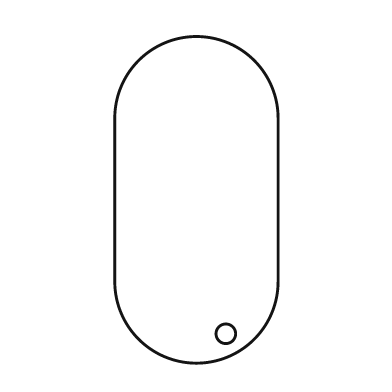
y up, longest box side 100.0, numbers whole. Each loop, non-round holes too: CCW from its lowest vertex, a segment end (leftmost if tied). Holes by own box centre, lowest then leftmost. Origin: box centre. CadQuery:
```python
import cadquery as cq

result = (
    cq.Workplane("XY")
    .moveTo(-25.0, -25.0)
    .threePointArc((0.0, -50.0), (25.0, -25.0))
    .lineTo(25.0, 25.0)
    .threePointArc((0.0, 50.0), (-25.0, 25.0))
    .close()
    .moveTo(9.0, -41.0)
    .circle(3.0)
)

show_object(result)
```